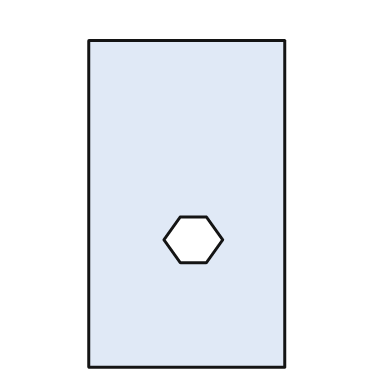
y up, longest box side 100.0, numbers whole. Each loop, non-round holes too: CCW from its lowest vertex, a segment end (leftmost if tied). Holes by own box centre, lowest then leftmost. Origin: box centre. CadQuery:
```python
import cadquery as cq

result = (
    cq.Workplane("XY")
    .moveTo(-30.0, -50.0)
    .lineTo(30.0, -50.0)
    .lineTo(30.0, 50.0)
    .lineTo(-30.0, 50.0)
    .close()
    .moveTo(-2.0, -18.0)
    .lineTo(6.0, -18.0)
    .lineTo(11.0, -11.0)
    .lineTo(6.0, -4.0)
    .lineTo(-2.0, -4.0)
    .lineTo(-7.0, -11.0)
    .close()
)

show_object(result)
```